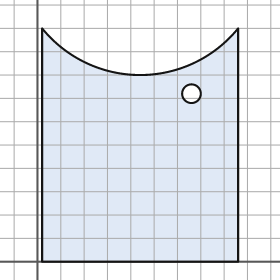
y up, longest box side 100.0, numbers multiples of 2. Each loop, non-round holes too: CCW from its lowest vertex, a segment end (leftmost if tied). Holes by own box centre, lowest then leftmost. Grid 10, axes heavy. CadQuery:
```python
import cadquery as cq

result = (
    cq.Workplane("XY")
    .moveTo(2.0, 0.0)
    .lineTo(86.0, 0.0)
    .lineTo(86.0, 100.0)
    .threePointArc((44.0, 80.0), (2.0, 100.0))
    .close()
    .moveTo(66.0, 72.0)
    .circle(4.0)
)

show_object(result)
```